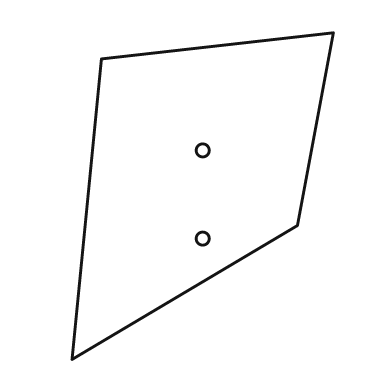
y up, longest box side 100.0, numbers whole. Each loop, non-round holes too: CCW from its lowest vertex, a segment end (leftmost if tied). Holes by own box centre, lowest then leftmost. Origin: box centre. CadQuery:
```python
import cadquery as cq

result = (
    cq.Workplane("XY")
    .moveTo(-40.0, -50.0)
    .lineTo(29.0, -9.0)
    .lineTo(40.0, 50.0)
    .lineTo(-31.0, 42.0)
    .close()
    .moveTo(0.0, -13.0)
    .circle(2.0)
    .moveTo(0.0, 14.0)
    .circle(2.0)
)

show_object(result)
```